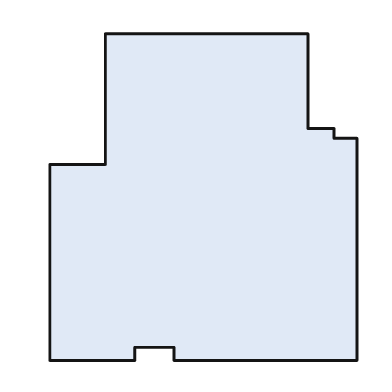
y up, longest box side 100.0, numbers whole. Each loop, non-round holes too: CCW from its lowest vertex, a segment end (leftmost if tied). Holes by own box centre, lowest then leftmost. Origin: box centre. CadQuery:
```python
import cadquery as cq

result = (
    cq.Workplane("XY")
    .moveTo(-47.0, -50.0)
    .lineTo(-21.0, -50.0)
    .lineTo(-21.0, -46.0)
    .lineTo(-9.0, -46.0)
    .lineTo(-9.0, -50.0)
    .lineTo(47.0, -50.0)
    .lineTo(47.0, 18.0)
    .lineTo(40.0, 18.0)
    .lineTo(40.0, 21.0)
    .lineTo(32.0, 21.0)
    .lineTo(32.0, 50.0)
    .lineTo(-30.0, 50.0)
    .lineTo(-30.0, 10.0)
    .lineTo(-47.0, 10.0)
    .close()
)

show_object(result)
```